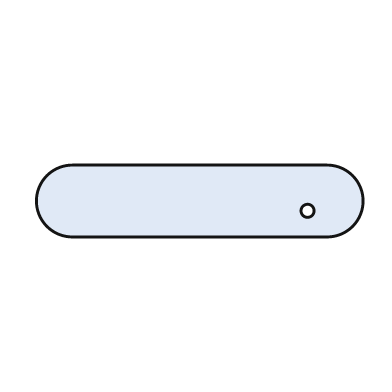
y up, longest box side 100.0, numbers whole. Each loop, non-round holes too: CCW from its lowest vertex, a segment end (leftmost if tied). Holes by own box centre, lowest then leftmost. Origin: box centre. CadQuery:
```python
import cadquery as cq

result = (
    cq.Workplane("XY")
    .moveTo(-39.0, -11.0)
    .lineTo(39.0, -11.0)
    .threePointArc((50.0, 0.0), (39.0, 11.0))
    .lineTo(-39.0, 11.0)
    .threePointArc((-50.0, 0.0), (-39.0, -11.0))
    .close()
    .moveTo(33.0, -3.0)
    .circle(2.0)
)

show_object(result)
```